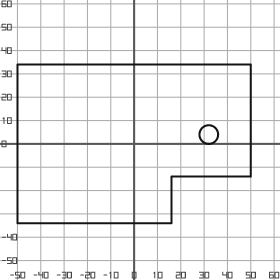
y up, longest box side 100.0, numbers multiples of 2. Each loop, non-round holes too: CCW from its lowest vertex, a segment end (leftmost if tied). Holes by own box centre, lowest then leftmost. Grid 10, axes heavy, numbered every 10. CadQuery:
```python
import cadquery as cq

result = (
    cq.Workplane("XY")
    .moveTo(-50.0, -34.0)
    .lineTo(16.0, -34.0)
    .lineTo(16.0, -14.0)
    .lineTo(50.0, -14.0)
    .lineTo(50.0, 34.0)
    .lineTo(-50.0, 34.0)
    .close()
    .moveTo(32.0, 4.0)
    .circle(4.0)
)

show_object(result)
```